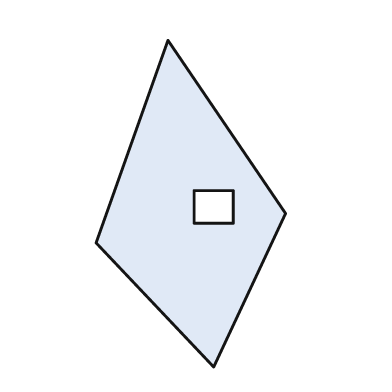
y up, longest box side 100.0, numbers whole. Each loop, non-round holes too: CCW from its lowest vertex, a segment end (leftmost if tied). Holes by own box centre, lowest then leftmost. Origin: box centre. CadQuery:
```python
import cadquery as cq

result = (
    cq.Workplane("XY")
    .moveTo(7.0, -50.0)
    .lineTo(29.0, -3.0)
    .lineTo(-7.0, 50.0)
    .lineTo(-29.0, -12.0)
    .close()
    .moveTo(1.0, -6.0)
    .lineTo(13.0, -6.0)
    .lineTo(13.0, 4.0)
    .lineTo(1.0, 4.0)
    .close()
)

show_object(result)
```